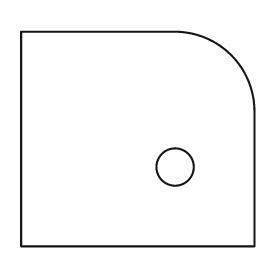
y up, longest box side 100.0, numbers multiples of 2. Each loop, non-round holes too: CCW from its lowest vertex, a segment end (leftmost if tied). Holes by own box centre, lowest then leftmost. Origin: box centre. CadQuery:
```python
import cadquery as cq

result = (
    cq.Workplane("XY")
    .moveTo(-50.0, -46.0)
    .lineTo(50.0, -46.0)
    .lineTo(50.0, 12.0)
    .threePointArc((40.0, 36.0), (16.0, 46.0))
    .lineTo(-50.0, 46.0)
    .close()
    .moveTo(16.0, -12.0)
    .circle(8.0)
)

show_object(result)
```